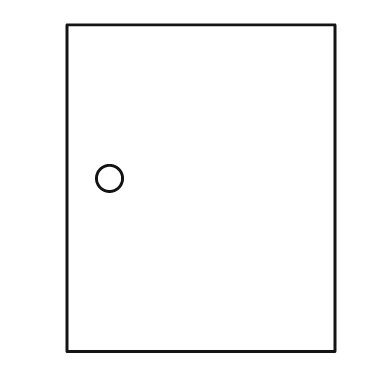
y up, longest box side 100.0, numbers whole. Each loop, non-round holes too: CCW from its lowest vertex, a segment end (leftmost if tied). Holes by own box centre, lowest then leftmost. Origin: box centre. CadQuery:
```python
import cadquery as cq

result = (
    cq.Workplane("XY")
    .moveTo(-41.0, -50.0)
    .lineTo(41.0, -50.0)
    .lineTo(41.0, 50.0)
    .lineTo(-41.0, 50.0)
    .close()
    .moveTo(-28.0, 3.0)
    .circle(4.0)
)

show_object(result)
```